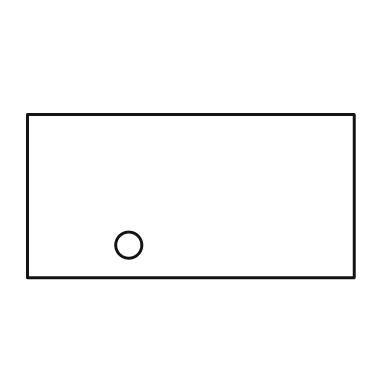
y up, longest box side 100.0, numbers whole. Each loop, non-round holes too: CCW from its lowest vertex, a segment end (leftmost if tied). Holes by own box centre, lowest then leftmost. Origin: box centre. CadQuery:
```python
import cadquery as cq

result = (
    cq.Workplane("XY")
    .moveTo(-50.0, -25.0)
    .lineTo(50.0, -25.0)
    .lineTo(50.0, 25.0)
    .lineTo(-50.0, 25.0)
    .close()
    .moveTo(-19.0, -15.0)
    .circle(4.0)
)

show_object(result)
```